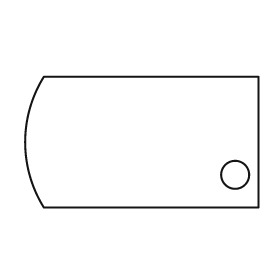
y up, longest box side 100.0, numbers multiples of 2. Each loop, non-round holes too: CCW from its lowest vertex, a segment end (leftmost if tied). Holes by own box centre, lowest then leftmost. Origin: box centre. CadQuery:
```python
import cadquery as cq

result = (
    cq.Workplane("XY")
    .moveTo(-42.0, -28.0)
    .lineTo(50.0, -28.0)
    .lineTo(50.0, 28.0)
    .lineTo(-42.0, 28.0)
    .threePointArc((-50.0, 0.0), (-42.0, -28.0))
    .close()
    .moveTo(40.0, -14.0)
    .circle(6.0)
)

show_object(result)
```